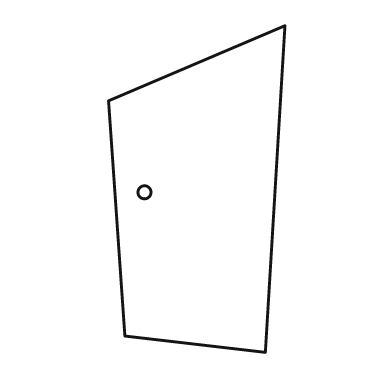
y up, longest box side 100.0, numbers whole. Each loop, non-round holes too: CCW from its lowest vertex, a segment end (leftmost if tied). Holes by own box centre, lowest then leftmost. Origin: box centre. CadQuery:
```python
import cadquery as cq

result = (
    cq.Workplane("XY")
    .moveTo(21.0, -50.0)
    .lineTo(27.0, 50.0)
    .lineTo(-27.0, 27.0)
    .lineTo(-22.0, -45.0)
    .close()
    .moveTo(-16.0, -1.0)
    .circle(2.0)
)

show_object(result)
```